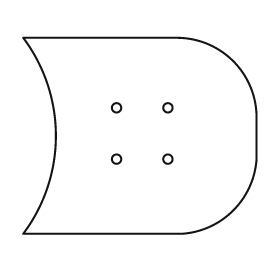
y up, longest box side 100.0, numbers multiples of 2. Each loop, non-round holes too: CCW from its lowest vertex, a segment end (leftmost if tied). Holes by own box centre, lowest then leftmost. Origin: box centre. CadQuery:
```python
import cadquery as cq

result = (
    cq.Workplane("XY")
    .moveTo(-50.0, -42.0)
    .lineTo(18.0, -42.0)
    .threePointArc((40.0, -32.0), (50.0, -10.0))
    .lineTo(50.0, 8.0)
    .threePointArc((40.0, 32.0), (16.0, 42.0))
    .lineTo(-50.0, 42.0)
    .threePointArc((-36.0, 0.0), (-50.0, -42.0))
    .close()
    .moveTo(-10.0, -10.0)
    .circle(2.0)
    .moveTo(12.0, -10.0)
    .circle(2.0)
    .moveTo(-10.0, 12.0)
    .circle(2.0)
    .moveTo(12.0, 12.0)
    .circle(2.0)
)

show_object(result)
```